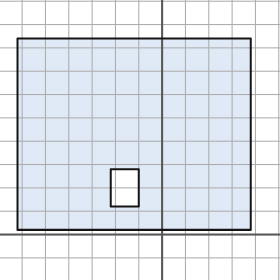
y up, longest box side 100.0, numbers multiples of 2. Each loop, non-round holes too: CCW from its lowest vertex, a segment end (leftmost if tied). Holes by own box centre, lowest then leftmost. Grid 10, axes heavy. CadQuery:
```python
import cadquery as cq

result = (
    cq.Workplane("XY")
    .moveTo(-62.0, 2.0)
    .lineTo(38.0, 2.0)
    .lineTo(38.0, 84.0)
    .lineTo(-62.0, 84.0)
    .close()
    .moveTo(-22.0, 12.0)
    .lineTo(-10.0, 12.0)
    .lineTo(-10.0, 28.0)
    .lineTo(-22.0, 28.0)
    .close()
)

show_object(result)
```